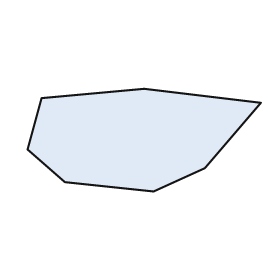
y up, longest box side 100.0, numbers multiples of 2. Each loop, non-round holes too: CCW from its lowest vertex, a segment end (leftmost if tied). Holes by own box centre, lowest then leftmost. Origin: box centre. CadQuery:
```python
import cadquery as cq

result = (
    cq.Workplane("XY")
    .moveTo(4.0, -22.0)
    .lineTo(26.0, -12.0)
    .lineTo(50.0, 16.0)
    .lineTo(0.0, 22.0)
    .lineTo(-44.0, 18.0)
    .lineTo(-50.0, -4.0)
    .lineTo(-34.0, -18.0)
    .close()
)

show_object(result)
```